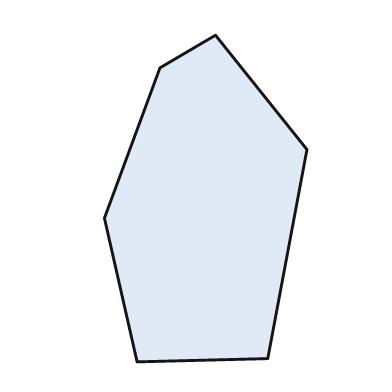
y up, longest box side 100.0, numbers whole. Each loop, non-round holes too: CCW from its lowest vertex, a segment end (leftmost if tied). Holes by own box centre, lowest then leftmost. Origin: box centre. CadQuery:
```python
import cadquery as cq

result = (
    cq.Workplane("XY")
    .moveTo(-21.0, -50.0)
    .lineTo(19.0, -49.0)
    .lineTo(31.0, 15.0)
    .lineTo(3.0, 50.0)
    .lineTo(-14.0, 40.0)
    .lineTo(-31.0, -6.0)
    .close()
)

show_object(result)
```